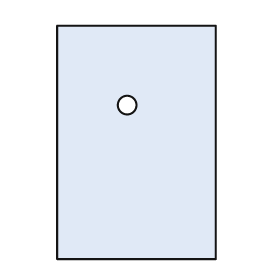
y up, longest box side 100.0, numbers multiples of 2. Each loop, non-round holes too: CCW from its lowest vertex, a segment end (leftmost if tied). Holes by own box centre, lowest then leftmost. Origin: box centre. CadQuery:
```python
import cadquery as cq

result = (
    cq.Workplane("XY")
    .moveTo(-34.0, -50.0)
    .lineTo(34.0, -50.0)
    .lineTo(34.0, 50.0)
    .lineTo(-34.0, 50.0)
    .close()
    .moveTo(-4.0, 16.0)
    .circle(4.0)
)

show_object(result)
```